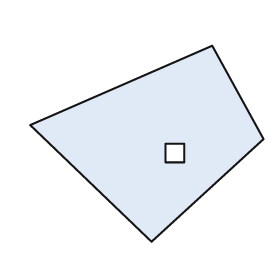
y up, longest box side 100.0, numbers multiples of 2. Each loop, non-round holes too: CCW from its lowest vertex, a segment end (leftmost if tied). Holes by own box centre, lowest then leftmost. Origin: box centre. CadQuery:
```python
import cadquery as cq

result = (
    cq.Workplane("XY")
    .moveTo(2.0, -42.0)
    .lineTo(50.0, 2.0)
    .lineTo(28.0, 42.0)
    .lineTo(-50.0, 8.0)
    .close()
    .moveTo(8.0, -8.0)
    .lineTo(16.0, -8.0)
    .lineTo(16.0, 0.0)
    .lineTo(8.0, 0.0)
    .close()
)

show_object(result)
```